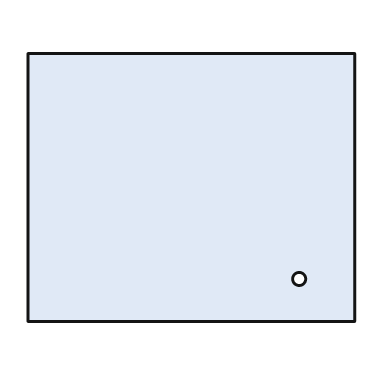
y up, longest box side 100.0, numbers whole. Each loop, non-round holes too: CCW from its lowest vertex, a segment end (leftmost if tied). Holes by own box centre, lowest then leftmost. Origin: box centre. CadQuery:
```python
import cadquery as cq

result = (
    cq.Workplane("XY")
    .moveTo(-50.0, -41.0)
    .lineTo(50.0, -41.0)
    .lineTo(50.0, 41.0)
    .lineTo(-50.0, 41.0)
    .close()
    .moveTo(33.0, -28.0)
    .circle(2.0)
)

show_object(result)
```